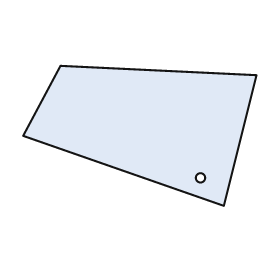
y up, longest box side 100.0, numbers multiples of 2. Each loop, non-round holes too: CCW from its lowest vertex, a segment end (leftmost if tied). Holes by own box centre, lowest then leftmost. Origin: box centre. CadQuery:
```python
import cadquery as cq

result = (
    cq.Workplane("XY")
    .moveTo(36.0, -30.0)
    .lineTo(50.0, 26.0)
    .lineTo(-34.0, 30.0)
    .lineTo(-50.0, 0.0)
    .close()
    .moveTo(26.0, -18.0)
    .circle(2.0)
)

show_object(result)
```